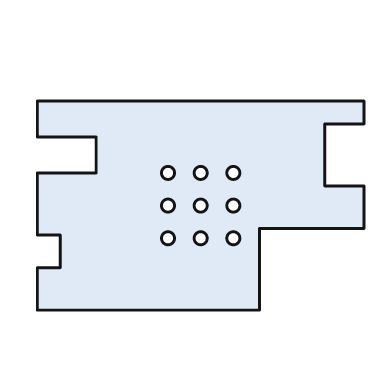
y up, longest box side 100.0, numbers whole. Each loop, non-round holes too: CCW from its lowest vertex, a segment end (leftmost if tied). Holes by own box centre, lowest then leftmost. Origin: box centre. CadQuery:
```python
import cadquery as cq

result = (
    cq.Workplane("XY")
    .moveTo(-50.0, -32.0)
    .lineTo(18.0, -32.0)
    .lineTo(18.0, -7.0)
    .lineTo(50.0, -7.0)
    .lineTo(50.0, 6.0)
    .lineTo(38.0, 6.0)
    .lineTo(38.0, 25.0)
    .lineTo(50.0, 25.0)
    .lineTo(50.0, 32.0)
    .lineTo(-50.0, 32.0)
    .lineTo(-50.0, 21.0)
    .lineTo(-32.0, 21.0)
    .lineTo(-32.0, 10.0)
    .lineTo(-50.0, 10.0)
    .lineTo(-50.0, -9.0)
    .lineTo(-43.0, -9.0)
    .lineTo(-43.0, -19.0)
    .lineTo(-50.0, -19.0)
    .close()
    .moveTo(-10.0, -10.0)
    .circle(2.0)
    .moveTo(0.0, -10.0)
    .circle(2.0)
    .moveTo(10.0, -10.0)
    .circle(2.0)
    .moveTo(-10.0, 0.0)
    .circle(2.0)
    .moveTo(0.0, 0.0)
    .circle(2.0)
    .moveTo(10.0, 0.0)
    .circle(2.0)
    .moveTo(-10.0, 10.0)
    .circle(2.0)
    .moveTo(0.0, 10.0)
    .circle(2.0)
    .moveTo(10.0, 10.0)
    .circle(2.0)
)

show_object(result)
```